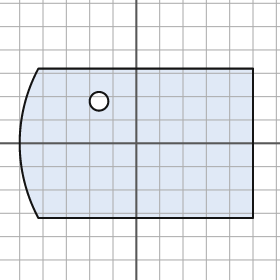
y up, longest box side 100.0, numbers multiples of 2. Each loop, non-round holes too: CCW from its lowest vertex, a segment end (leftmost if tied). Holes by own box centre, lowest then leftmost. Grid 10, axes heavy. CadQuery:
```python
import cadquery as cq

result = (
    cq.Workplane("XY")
    .moveTo(-42.0, -32.0)
    .lineTo(50.0, -32.0)
    .lineTo(50.0, 32.0)
    .lineTo(-42.0, 32.0)
    .threePointArc((-50.0, 0.0), (-42.0, -32.0))
    .close()
    .moveTo(-16.0, 18.0)
    .circle(4.0)
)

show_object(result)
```